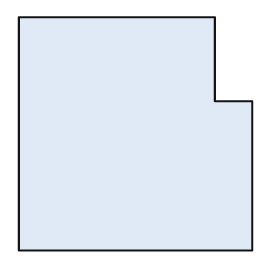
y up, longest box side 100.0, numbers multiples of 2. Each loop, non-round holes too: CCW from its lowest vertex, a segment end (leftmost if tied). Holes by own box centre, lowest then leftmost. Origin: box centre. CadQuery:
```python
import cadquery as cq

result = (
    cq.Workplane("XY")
    .moveTo(-50.0, -50.0)
    .lineTo(50.0, -50.0)
    .lineTo(50.0, 14.0)
    .lineTo(34.0, 14.0)
    .lineTo(34.0, 50.0)
    .lineTo(-50.0, 50.0)
    .close()
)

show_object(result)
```